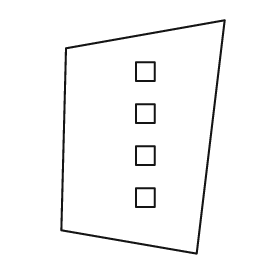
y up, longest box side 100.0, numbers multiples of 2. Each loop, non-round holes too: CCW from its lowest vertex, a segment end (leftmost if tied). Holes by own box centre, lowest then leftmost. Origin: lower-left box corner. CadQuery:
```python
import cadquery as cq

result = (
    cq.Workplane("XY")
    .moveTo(58.0, 0.0)
    .lineTo(70.0, 100.0)
    .lineTo(2.0, 88.0)
    .lineTo(0.0, 10.0)
    .close()
    .moveTo(32.0, 20.0)
    .lineTo(40.0, 20.0)
    .lineTo(40.0, 28.0)
    .lineTo(32.0, 28.0)
    .close()
    .moveTo(32.0, 38.0)
    .lineTo(40.0, 38.0)
    .lineTo(40.0, 46.0)
    .lineTo(32.0, 46.0)
    .close()
    .moveTo(32.0, 56.0)
    .lineTo(40.0, 56.0)
    .lineTo(40.0, 64.0)
    .lineTo(32.0, 64.0)
    .close()
    .moveTo(32.0, 74.0)
    .lineTo(40.0, 74.0)
    .lineTo(40.0, 82.0)
    .lineTo(32.0, 82.0)
    .close()
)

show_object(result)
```